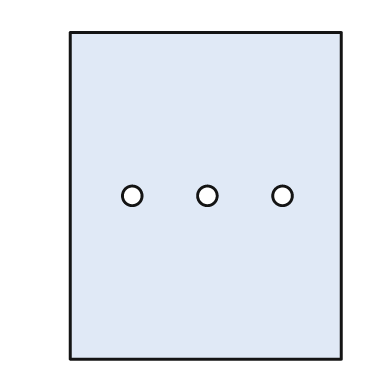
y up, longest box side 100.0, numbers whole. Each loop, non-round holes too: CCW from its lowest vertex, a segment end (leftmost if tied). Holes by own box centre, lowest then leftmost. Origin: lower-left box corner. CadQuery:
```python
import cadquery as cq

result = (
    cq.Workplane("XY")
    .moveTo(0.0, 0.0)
    .lineTo(83.0, 0.0)
    .lineTo(83.0, 100.0)
    .lineTo(0.0, 100.0)
    .close()
    .moveTo(19.0, 50.0)
    .circle(3.0)
    .moveTo(42.0, 50.0)
    .circle(3.0)
    .moveTo(65.0, 50.0)
    .circle(3.0)
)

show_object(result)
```